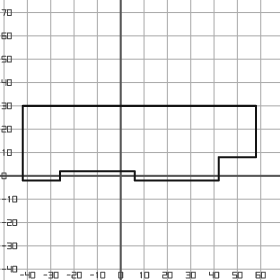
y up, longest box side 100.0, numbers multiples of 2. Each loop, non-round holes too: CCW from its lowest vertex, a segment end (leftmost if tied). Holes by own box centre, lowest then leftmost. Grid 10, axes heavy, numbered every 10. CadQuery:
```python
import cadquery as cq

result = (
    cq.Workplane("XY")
    .moveTo(-42.0, -2.0)
    .lineTo(-26.0, -2.0)
    .lineTo(-26.0, 2.0)
    .lineTo(6.0, 2.0)
    .lineTo(6.0, -2.0)
    .lineTo(42.0, -2.0)
    .lineTo(42.0, 8.0)
    .lineTo(58.0, 8.0)
    .lineTo(58.0, 30.0)
    .lineTo(-42.0, 30.0)
    .close()
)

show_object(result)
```